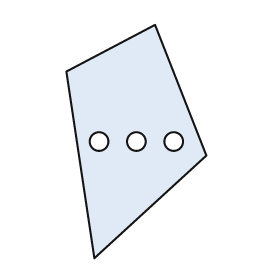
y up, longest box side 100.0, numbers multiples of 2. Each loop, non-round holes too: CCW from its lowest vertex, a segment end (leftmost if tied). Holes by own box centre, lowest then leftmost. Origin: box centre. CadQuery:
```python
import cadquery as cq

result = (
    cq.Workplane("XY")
    .moveTo(-18.0, -50.0)
    .lineTo(30.0, -6.0)
    .lineTo(8.0, 50.0)
    .lineTo(-30.0, 30.0)
    .close()
    .moveTo(-16.0, 0.0)
    .circle(4.0)
    .moveTo(0.0, 0.0)
    .circle(4.0)
    .moveTo(16.0, 0.0)
    .circle(4.0)
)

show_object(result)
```